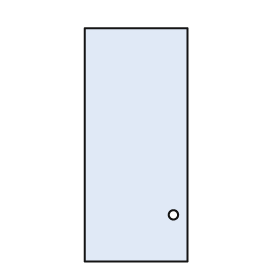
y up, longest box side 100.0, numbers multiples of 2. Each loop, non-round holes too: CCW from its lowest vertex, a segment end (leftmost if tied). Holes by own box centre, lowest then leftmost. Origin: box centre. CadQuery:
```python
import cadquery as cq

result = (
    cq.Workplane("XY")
    .moveTo(-22.0, -50.0)
    .lineTo(22.0, -50.0)
    .lineTo(22.0, 50.0)
    .lineTo(-22.0, 50.0)
    .close()
    .moveTo(16.0, -30.0)
    .circle(2.0)
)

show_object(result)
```